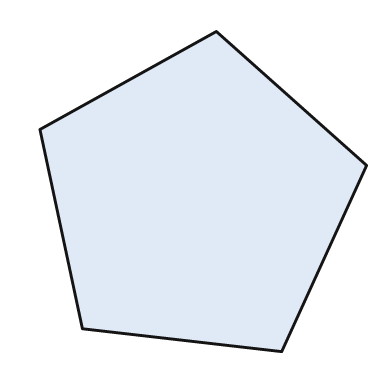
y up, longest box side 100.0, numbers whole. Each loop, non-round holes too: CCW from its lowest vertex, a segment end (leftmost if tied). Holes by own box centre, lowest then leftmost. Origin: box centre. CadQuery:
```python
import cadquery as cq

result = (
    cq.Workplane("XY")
    .moveTo(24.0, -49.0)
    .lineTo(50.0, 8.0)
    .lineTo(4.0, 49.0)
    .lineTo(-50.0, 19.0)
    .lineTo(-37.0, -42.0)
    .close()
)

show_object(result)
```